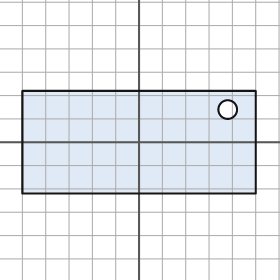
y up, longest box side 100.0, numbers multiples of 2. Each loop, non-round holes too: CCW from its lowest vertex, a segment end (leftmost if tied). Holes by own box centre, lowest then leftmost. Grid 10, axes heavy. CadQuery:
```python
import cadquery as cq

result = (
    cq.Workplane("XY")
    .moveTo(-50.0, -22.0)
    .lineTo(50.0, -22.0)
    .lineTo(50.0, 22.0)
    .lineTo(-50.0, 22.0)
    .close()
    .moveTo(38.0, 14.0)
    .circle(4.0)
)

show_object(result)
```